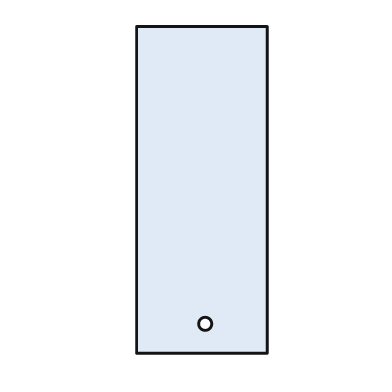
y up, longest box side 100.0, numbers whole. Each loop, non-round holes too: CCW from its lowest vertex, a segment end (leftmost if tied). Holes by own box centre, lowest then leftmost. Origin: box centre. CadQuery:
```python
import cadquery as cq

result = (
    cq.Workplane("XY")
    .moveTo(-20.0, -50.0)
    .lineTo(20.0, -50.0)
    .lineTo(20.0, 50.0)
    .lineTo(-20.0, 50.0)
    .close()
    .moveTo(1.0, -41.0)
    .circle(2.0)
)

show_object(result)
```